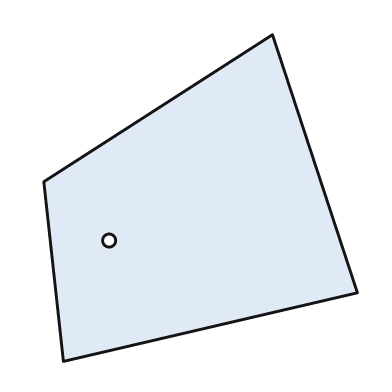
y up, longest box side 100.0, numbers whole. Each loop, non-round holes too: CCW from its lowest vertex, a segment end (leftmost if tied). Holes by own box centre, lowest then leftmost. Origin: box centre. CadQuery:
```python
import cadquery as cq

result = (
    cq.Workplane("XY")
    .moveTo(-42.0, -50.0)
    .lineTo(48.0, -29.0)
    .lineTo(22.0, 50.0)
    .lineTo(-48.0, 5.0)
    .close()
    .moveTo(-28.0, -13.0)
    .circle(2.0)
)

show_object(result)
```